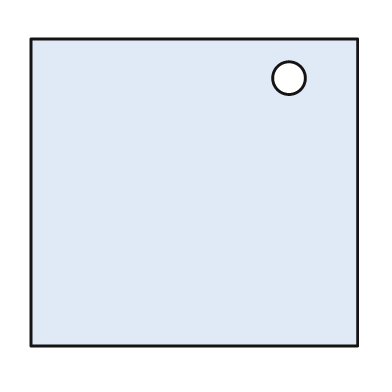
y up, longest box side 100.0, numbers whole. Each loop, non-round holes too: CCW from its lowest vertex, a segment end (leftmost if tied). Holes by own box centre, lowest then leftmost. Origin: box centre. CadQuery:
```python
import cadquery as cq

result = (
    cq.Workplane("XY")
    .moveTo(-50.0, -47.0)
    .lineTo(50.0, -47.0)
    .lineTo(50.0, 47.0)
    .lineTo(-50.0, 47.0)
    .close()
    .moveTo(29.0, 35.0)
    .circle(5.0)
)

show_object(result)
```